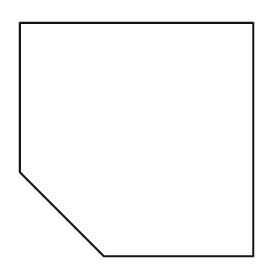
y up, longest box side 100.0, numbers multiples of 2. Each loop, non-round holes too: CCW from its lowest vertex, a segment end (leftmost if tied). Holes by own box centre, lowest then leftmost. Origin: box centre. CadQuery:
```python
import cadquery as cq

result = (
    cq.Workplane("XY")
    .moveTo(-14.0, -50.0)
    .lineTo(50.0, -50.0)
    .lineTo(50.0, 50.0)
    .lineTo(-50.0, 50.0)
    .lineTo(-50.0, -14.0)
    .close()
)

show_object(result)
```